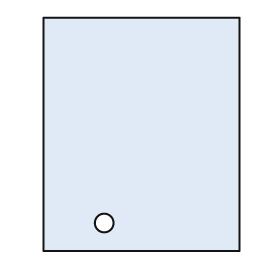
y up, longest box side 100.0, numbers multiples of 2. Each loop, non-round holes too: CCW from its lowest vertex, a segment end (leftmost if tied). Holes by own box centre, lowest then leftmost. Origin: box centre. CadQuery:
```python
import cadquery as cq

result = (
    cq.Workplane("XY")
    .moveTo(-42.0, -50.0)
    .lineTo(42.0, -50.0)
    .lineTo(42.0, 50.0)
    .lineTo(-42.0, 50.0)
    .close()
    .moveTo(-16.0, -38.0)
    .circle(4.0)
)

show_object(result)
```